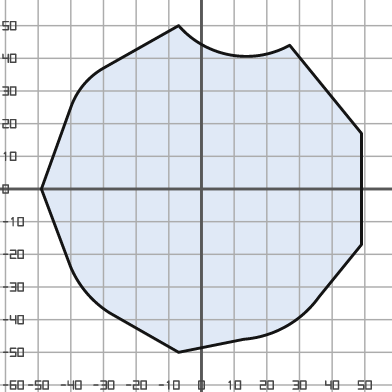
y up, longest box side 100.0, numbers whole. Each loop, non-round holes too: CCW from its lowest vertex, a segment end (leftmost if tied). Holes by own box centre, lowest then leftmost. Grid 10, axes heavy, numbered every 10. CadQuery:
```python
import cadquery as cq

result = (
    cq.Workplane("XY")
    .moveTo(-7.0, -50.0)
    .lineTo(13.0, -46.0)
    .threePointArc((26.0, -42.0), (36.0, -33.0))
    .lineTo(49.0, -17.0)
    .lineTo(49.0, 17.0)
    .lineTo(27.0, 44.0)
    .threePointArc((9.0, 41.0), (-7.0, 50.0))
    .lineTo(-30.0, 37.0)
    .threePointArc((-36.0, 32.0), (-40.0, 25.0))
    .lineTo(-49.0, 0.0)
    .lineTo(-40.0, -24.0)
    .threePointArc((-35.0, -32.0), (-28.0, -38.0))
    .close()
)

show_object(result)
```